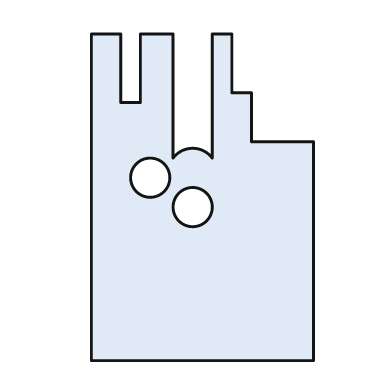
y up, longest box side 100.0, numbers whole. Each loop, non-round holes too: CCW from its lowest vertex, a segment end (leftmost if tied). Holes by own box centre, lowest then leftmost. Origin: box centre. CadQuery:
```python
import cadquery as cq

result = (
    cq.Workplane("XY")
    .moveTo(-34.0, -50.0)
    .lineTo(34.0, -50.0)
    .lineTo(34.0, 17.0)
    .lineTo(15.0, 17.0)
    .lineTo(15.0, 32.0)
    .lineTo(9.0, 32.0)
    .lineTo(9.0, 50.0)
    .lineTo(3.0, 50.0)
    .lineTo(3.0, 12.0)
    .threePointArc((-3.0, 15.0), (-9.0, 12.0))
    .lineTo(-9.0, 50.0)
    .lineTo(-19.0, 50.0)
    .lineTo(-19.0, 29.0)
    .lineTo(-25.0, 29.0)
    .lineTo(-25.0, 50.0)
    .lineTo(-34.0, 50.0)
    .close()
    .moveTo(-3.0, -3.0)
    .circle(6.0)
    .moveTo(-16.0, 6.0)
    .circle(6.0)
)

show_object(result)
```